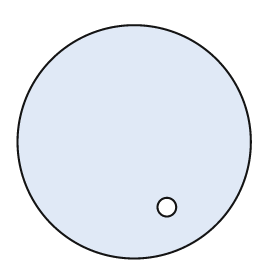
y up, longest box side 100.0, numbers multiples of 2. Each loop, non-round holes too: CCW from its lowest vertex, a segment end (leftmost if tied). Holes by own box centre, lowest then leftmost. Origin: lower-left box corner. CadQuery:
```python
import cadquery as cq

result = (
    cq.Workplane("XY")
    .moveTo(50.0, 50.0)
    .circle(50.0)
    .moveTo(64.0, 22.0)
    .circle(4.0)
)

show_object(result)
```